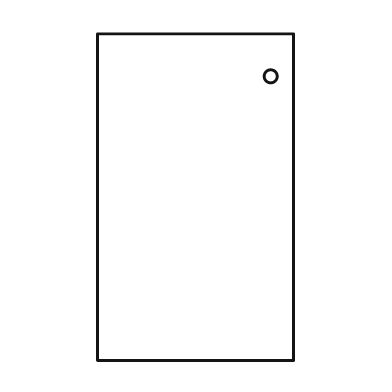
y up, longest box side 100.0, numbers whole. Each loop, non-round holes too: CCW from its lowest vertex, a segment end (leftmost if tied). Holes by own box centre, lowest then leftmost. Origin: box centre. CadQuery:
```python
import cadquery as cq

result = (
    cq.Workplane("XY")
    .moveTo(-30.0, -50.0)
    .lineTo(30.0, -50.0)
    .lineTo(30.0, 50.0)
    .lineTo(-30.0, 50.0)
    .close()
    .moveTo(23.0, 37.0)
    .circle(2.0)
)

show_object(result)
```